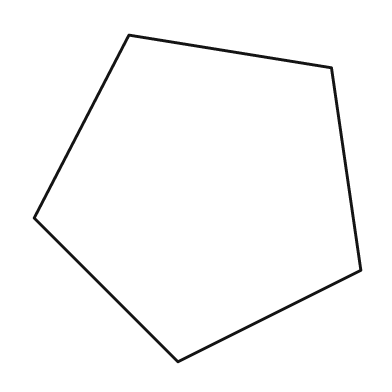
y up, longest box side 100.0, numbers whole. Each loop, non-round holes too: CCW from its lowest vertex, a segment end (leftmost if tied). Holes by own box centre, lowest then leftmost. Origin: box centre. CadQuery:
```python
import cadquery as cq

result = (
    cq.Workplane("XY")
    .moveTo(-6.0, -50.0)
    .lineTo(50.0, -22.0)
    .lineTo(41.0, 40.0)
    .lineTo(-21.0, 50.0)
    .lineTo(-50.0, -6.0)
    .close()
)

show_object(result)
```